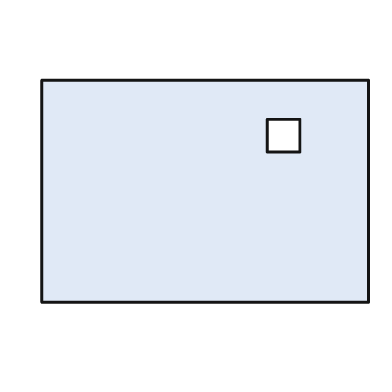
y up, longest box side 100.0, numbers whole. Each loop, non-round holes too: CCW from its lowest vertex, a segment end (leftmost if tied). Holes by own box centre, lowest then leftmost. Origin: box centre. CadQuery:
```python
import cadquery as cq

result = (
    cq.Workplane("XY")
    .moveTo(-50.0, -34.0)
    .lineTo(50.0, -34.0)
    .lineTo(50.0, 34.0)
    .lineTo(-50.0, 34.0)
    .close()
    .moveTo(19.0, 12.0)
    .lineTo(29.0, 12.0)
    .lineTo(29.0, 22.0)
    .lineTo(19.0, 22.0)
    .close()
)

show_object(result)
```